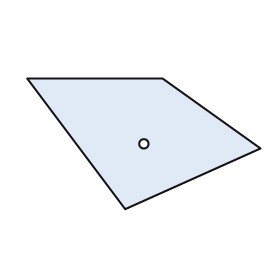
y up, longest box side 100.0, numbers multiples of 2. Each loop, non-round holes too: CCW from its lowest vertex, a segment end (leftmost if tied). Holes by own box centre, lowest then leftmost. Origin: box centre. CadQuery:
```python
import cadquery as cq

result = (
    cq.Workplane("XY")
    .moveTo(-8.0, -28.0)
    .lineTo(50.0, -2.0)
    .lineTo(8.0, 28.0)
    .lineTo(-50.0, 28.0)
    .close()
    .moveTo(0.0, 0.0)
    .circle(2.0)
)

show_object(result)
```